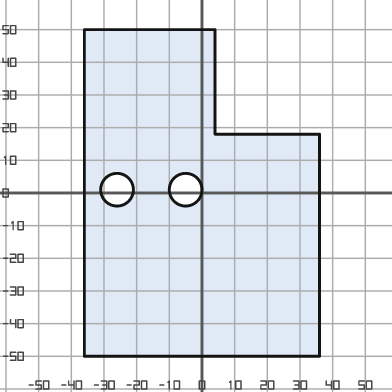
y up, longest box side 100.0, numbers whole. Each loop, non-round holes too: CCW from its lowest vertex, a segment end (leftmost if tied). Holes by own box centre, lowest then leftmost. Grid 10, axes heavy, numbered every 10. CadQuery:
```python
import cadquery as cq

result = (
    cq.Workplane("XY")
    .moveTo(-36.0, -50.0)
    .lineTo(36.0, -50.0)
    .lineTo(36.0, 18.0)
    .lineTo(4.0, 18.0)
    .lineTo(4.0, 50.0)
    .lineTo(-36.0, 50.0)
    .close()
    .moveTo(-26.0, 1.0)
    .circle(5.0)
    .moveTo(-5.0, 1.0)
    .circle(5.0)
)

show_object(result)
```